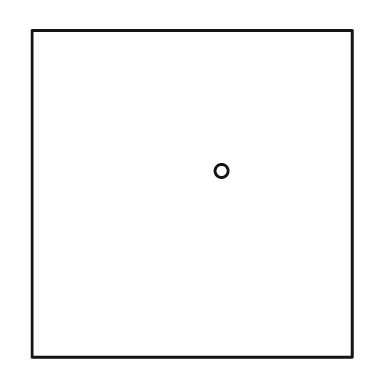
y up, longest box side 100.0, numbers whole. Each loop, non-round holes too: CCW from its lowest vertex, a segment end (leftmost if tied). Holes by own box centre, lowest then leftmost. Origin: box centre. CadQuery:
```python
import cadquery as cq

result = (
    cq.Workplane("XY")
    .moveTo(-49.0, -50.0)
    .lineTo(49.0, -50.0)
    .lineTo(49.0, 50.0)
    .lineTo(-49.0, 50.0)
    .close()
    .moveTo(9.0, 7.0)
    .circle(2.0)
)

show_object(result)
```